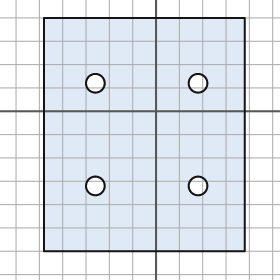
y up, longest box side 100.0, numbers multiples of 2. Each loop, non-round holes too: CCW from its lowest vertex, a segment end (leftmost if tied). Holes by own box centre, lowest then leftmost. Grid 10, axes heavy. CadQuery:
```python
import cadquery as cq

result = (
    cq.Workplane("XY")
    .moveTo(-48.0, -60.0)
    .lineTo(38.0, -60.0)
    .lineTo(38.0, 40.0)
    .lineTo(-48.0, 40.0)
    .close()
    .moveTo(-26.0, -32.0)
    .circle(4.0)
    .moveTo(18.0, -32.0)
    .circle(4.0)
    .moveTo(-26.0, 12.0)
    .circle(4.0)
    .moveTo(18.0, 12.0)
    .circle(4.0)
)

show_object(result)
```